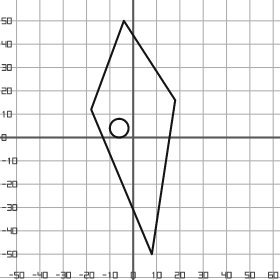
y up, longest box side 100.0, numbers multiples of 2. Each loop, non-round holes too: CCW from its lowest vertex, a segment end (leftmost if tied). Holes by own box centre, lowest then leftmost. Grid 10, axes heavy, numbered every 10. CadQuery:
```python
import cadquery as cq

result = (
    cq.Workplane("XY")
    .moveTo(8.0, -50.0)
    .lineTo(18.0, 16.0)
    .lineTo(-4.0, 50.0)
    .lineTo(-18.0, 12.0)
    .close()
    .moveTo(-6.0, 4.0)
    .circle(4.0)
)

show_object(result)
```